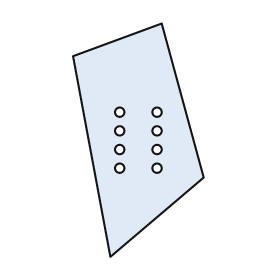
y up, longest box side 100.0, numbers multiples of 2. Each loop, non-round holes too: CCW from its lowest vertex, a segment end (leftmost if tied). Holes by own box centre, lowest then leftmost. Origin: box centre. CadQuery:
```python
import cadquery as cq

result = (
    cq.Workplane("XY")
    .moveTo(-12.0, -50.0)
    .lineTo(28.0, -16.0)
    .lineTo(10.0, 50.0)
    .lineTo(-28.0, 36.0)
    .close()
    .moveTo(-8.0, -12.0)
    .circle(2.0)
    .moveTo(8.0, -12.0)
    .circle(2.0)
    .moveTo(-8.0, -4.0)
    .circle(2.0)
    .moveTo(8.0, -4.0)
    .circle(2.0)
    .moveTo(-8.0, 4.0)
    .circle(2.0)
    .moveTo(8.0, 4.0)
    .circle(2.0)
    .moveTo(-8.0, 12.0)
    .circle(2.0)
    .moveTo(8.0, 12.0)
    .circle(2.0)
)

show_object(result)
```